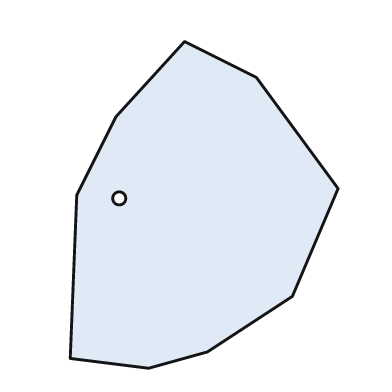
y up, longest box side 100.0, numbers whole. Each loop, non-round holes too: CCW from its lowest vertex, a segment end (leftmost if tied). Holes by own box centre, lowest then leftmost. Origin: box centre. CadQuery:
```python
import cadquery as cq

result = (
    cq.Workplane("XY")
    .moveTo(-17.0, -50.0)
    .lineTo(1.0, -45.0)
    .lineTo(27.0, -28.0)
    .lineTo(41.0, 5.0)
    .lineTo(16.0, 39.0)
    .lineTo(-6.0, 50.0)
    .lineTo(-27.0, 27.0)
    .lineTo(-39.0, 3.0)
    .lineTo(-41.0, -47.0)
    .close()
    .moveTo(-26.0, 2.0)
    .circle(2.0)
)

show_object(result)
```